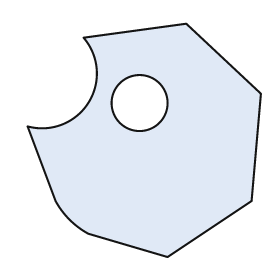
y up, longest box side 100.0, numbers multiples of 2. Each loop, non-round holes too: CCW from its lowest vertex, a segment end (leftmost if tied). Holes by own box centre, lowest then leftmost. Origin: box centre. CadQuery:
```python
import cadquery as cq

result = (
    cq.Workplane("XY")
    .moveTo(10.0, -50.0)
    .lineTo(46.0, -26.0)
    .lineTo(50.0, 20.0)
    .lineTo(18.0, 50.0)
    .lineTo(-26.0, 44.0)
    .threePointArc((-24.0, 16.0), (-50.0, 6.0))
    .lineTo(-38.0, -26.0)
    .threePointArc((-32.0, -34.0), (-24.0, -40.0))
    .close()
    .moveTo(-2.0, 16.0)
    .circle(12.0)
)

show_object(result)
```